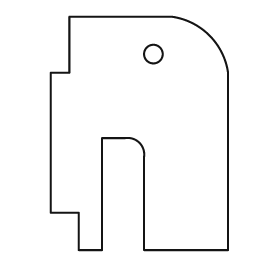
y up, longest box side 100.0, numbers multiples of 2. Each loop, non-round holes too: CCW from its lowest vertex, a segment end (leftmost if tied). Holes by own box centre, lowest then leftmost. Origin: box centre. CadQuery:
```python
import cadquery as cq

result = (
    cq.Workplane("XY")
    .moveTo(-26.0, -50.0)
    .lineTo(-16.0, -50.0)
    .lineTo(-16.0, -2.0)
    .lineTo(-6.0, -2.0)
    .threePointArc((0.0, -4.0), (2.0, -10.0))
    .lineTo(2.0, -50.0)
    .lineTo(38.0, -50.0)
    .lineTo(38.0, 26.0)
    .threePointArc((30.0, 42.0), (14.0, 50.0))
    .lineTo(-30.0, 50.0)
    .lineTo(-30.0, 26.0)
    .lineTo(-38.0, 26.0)
    .lineTo(-38.0, -34.0)
    .lineTo(-26.0, -34.0)
    .close()
    .moveTo(6.0, 34.0)
    .circle(4.0)
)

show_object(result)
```